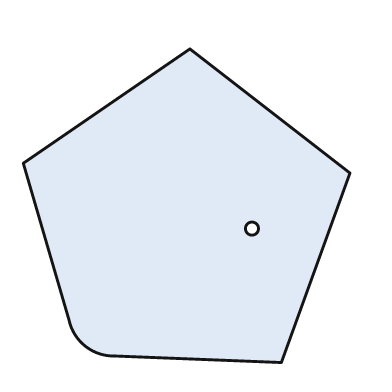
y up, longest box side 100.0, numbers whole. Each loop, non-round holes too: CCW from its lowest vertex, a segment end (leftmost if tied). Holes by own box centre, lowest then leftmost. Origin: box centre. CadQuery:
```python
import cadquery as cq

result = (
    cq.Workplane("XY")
    .moveTo(29.0, -48.0)
    .lineTo(50.0, 10.0)
    .lineTo(1.0, 48.0)
    .lineTo(-50.0, 13.0)
    .lineTo(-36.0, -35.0)
    .threePointArc((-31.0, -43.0), (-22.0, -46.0))
    .close()
    .moveTo(20.0, -7.0)
    .circle(2.0)
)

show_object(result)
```